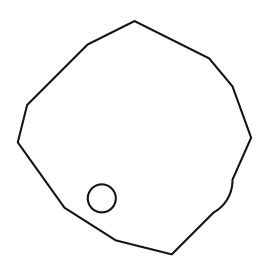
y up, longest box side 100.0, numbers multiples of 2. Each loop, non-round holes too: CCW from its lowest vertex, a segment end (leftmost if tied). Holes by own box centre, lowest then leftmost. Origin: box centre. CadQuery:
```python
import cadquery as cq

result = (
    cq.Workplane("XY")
    .moveTo(16.0, -50.0)
    .lineTo(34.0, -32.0)
    .threePointArc((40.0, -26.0), (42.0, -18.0))
    .lineTo(50.0, 0.0)
    .lineTo(42.0, 22.0)
    .lineTo(32.0, 34.0)
    .lineTo(0.0, 50.0)
    .lineTo(-20.0, 40.0)
    .lineTo(-46.0, 14.0)
    .lineTo(-50.0, -2.0)
    .lineTo(-30.0, -30.0)
    .lineTo(-8.0, -44.0)
    .close()
    .moveTo(-14.0, -26.0)
    .circle(6.0)
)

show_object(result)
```